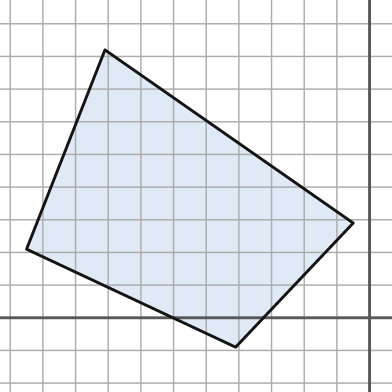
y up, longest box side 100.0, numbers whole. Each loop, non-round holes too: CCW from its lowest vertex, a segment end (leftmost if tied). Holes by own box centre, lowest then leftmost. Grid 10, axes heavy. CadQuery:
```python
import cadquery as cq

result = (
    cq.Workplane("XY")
    .moveTo(-41.0, -9.0)
    .lineTo(-5.0, 29.0)
    .lineTo(-81.0, 82.0)
    .lineTo(-105.0, 21.0)
    .close()
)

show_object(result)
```